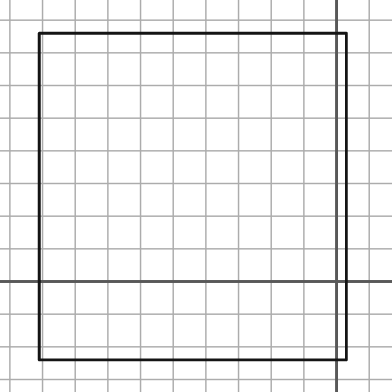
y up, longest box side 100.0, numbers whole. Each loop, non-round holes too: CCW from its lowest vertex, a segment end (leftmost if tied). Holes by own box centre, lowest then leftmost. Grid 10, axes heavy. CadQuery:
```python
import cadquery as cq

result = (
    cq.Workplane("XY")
    .moveTo(-91.0, -24.0)
    .lineTo(3.0, -24.0)
    .lineTo(3.0, 76.0)
    .lineTo(-91.0, 76.0)
    .close()
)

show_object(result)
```